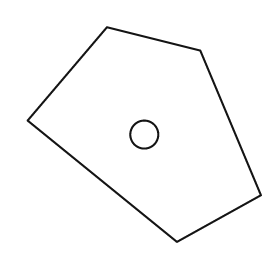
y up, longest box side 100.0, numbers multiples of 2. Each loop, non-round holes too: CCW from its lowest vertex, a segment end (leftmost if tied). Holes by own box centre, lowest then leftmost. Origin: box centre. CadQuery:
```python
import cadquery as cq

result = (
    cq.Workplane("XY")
    .moveTo(14.0, -46.0)
    .lineTo(50.0, -26.0)
    .lineTo(24.0, 36.0)
    .lineTo(-16.0, 46.0)
    .lineTo(-50.0, 6.0)
    .close()
    .moveTo(0.0, 0.0)
    .circle(6.0)
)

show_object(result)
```